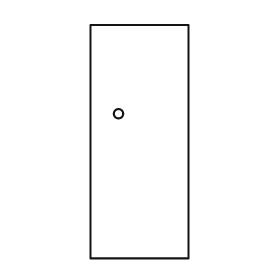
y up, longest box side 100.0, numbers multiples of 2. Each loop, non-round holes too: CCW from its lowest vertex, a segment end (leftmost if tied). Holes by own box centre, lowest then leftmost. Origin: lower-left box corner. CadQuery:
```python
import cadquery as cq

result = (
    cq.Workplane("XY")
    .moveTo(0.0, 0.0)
    .lineTo(42.0, 0.0)
    .lineTo(42.0, 100.0)
    .lineTo(0.0, 100.0)
    .close()
    .moveTo(12.0, 62.0)
    .circle(2.0)
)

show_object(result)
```